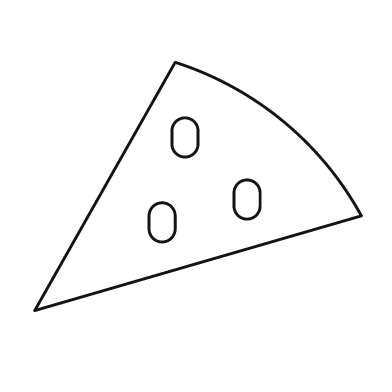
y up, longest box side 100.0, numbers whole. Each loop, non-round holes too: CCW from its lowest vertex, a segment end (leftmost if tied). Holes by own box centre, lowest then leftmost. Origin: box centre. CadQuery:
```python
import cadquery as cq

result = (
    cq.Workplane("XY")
    .moveTo(-50.0, -38.0)
    .lineTo(50.0, -9.0)
    .threePointArc((26.0, 20.0), (-7.0, 38.0))
    .close()
    .moveTo(-15.0, -13.0)
    .threePointArc((-11.0, -17.0), (-7.0, -13.0))
    .lineTo(-7.0, -9.0)
    .threePointArc((-11.0, -5.0), (-15.0, -9.0))
    .close()
    .moveTo(11.0, -6.0)
    .threePointArc((15.0, -10.0), (19.0, -6.0))
    .lineTo(19.0, -2.0)
    .threePointArc((15.0, 2.0), (11.0, -2.0))
    .close()
    .moveTo(-8.0, 13.0)
    .threePointArc((-4.0, 9.0), (0.0, 13.0))
    .lineTo(0.0, 17.0)
    .threePointArc((-4.0, 21.0), (-8.0, 17.0))
    .close()
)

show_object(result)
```